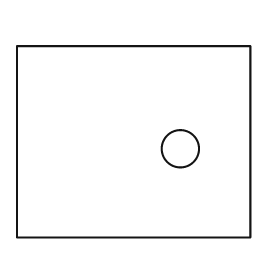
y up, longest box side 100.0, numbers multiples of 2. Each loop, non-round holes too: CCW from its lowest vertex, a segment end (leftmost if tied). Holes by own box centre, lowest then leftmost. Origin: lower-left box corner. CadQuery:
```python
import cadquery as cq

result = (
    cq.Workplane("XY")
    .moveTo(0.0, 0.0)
    .lineTo(100.0, 0.0)
    .lineTo(100.0, 82.0)
    .lineTo(0.0, 82.0)
    .close()
    .moveTo(70.0, 38.0)
    .circle(8.0)
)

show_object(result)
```